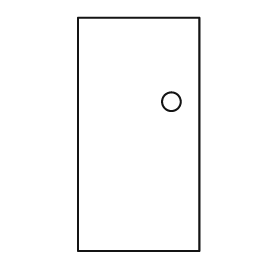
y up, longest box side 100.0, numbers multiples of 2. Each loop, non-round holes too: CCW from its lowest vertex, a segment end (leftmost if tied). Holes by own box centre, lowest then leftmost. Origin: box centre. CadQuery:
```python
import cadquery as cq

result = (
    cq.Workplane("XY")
    .moveTo(-26.0, -50.0)
    .lineTo(26.0, -50.0)
    .lineTo(26.0, 50.0)
    .lineTo(-26.0, 50.0)
    .close()
    .moveTo(14.0, 14.0)
    .circle(4.0)
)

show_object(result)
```